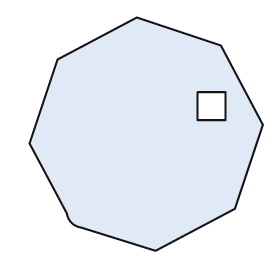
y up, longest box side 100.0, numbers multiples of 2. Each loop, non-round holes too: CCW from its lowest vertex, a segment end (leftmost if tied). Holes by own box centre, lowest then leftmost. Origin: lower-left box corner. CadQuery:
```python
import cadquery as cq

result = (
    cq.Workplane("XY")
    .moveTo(54.0, 0.0)
    .lineTo(88.0, 18.0)
    .lineTo(100.0, 54.0)
    .lineTo(82.0, 88.0)
    .lineTo(46.0, 100.0)
    .lineTo(12.0, 82.0)
    .lineTo(0.0, 46.0)
    .lineTo(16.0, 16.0)
    .threePointArc((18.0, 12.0), (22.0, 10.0))
    .close()
    .moveTo(72.0, 56.0)
    .lineTo(84.0, 56.0)
    .lineTo(84.0, 68.0)
    .lineTo(72.0, 68.0)
    .close()
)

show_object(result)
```